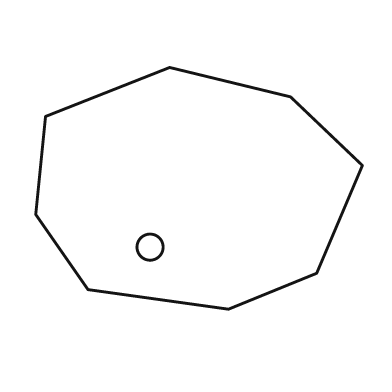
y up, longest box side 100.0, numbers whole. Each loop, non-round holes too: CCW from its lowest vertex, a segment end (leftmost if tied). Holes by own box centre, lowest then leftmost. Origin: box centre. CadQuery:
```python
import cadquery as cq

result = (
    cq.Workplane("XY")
    .moveTo(9.0, -37.0)
    .lineTo(36.0, -26.0)
    .lineTo(50.0, 7.0)
    .lineTo(28.0, 28.0)
    .lineTo(-9.0, 37.0)
    .lineTo(-47.0, 22.0)
    .lineTo(-50.0, -8.0)
    .lineTo(-34.0, -31.0)
    .close()
    .moveTo(-15.0, -18.0)
    .circle(4.0)
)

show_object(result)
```